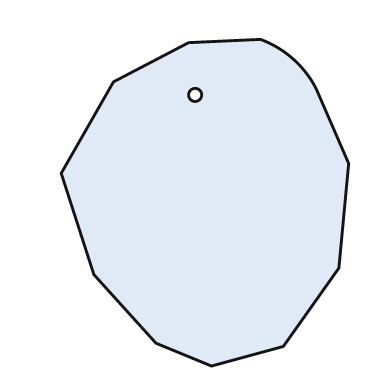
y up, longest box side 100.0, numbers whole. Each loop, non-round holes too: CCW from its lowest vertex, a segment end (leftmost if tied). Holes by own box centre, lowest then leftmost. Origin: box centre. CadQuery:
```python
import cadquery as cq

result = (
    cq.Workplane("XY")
    .moveTo(2.0, -50.0)
    .lineTo(24.0, -44.0)
    .lineTo(41.0, -20.0)
    .lineTo(44.0, 12.0)
    .lineTo(34.0, 35.0)
    .threePointArc((27.0, 44.0), (17.0, 50.0))
    .lineTo(-5.0, 49.0)
    .lineTo(-28.0, 37.0)
    .lineTo(-44.0, 9.0)
    .lineTo(-34.0, -22.0)
    .lineTo(-15.0, -43.0)
    .close()
    .moveTo(-3.0, 33.0)
    .circle(2.0)
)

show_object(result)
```